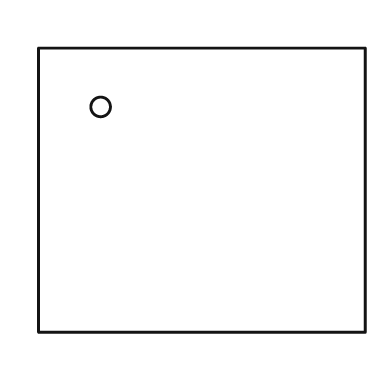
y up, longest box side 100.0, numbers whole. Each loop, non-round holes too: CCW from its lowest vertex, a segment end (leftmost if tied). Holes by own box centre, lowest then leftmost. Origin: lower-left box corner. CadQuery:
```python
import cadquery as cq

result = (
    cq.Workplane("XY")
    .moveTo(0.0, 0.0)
    .lineTo(100.0, 0.0)
    .lineTo(100.0, 87.0)
    .lineTo(0.0, 87.0)
    .close()
    .moveTo(19.0, 69.0)
    .circle(3.0)
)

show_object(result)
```